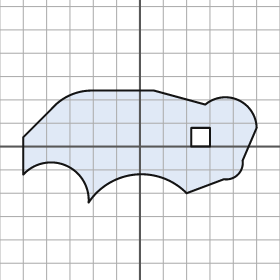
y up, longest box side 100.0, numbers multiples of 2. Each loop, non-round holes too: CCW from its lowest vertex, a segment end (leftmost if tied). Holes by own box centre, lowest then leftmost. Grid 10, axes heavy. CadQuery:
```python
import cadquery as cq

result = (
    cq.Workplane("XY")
    .moveTo(-22.0, -24.0)
    .threePointArc((-2.0, -12.0), (20.0, -20.0))
    .lineTo(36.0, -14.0)
    .threePointArc((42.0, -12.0), (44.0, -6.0))
    .lineTo(50.0, 8.0)
    .threePointArc((42.0, 20.0), (28.0, 18.0))
    .lineTo(6.0, 24.0)
    .lineTo(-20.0, 24.0)
    .threePointArc((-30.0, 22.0), (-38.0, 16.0))
    .lineTo(-50.0, 4.0)
    .lineTo(-50.0, -12.0)
    .threePointArc((-32.0, -8.0), (-22.0, -24.0))
    .close()
    .moveTo(22.0, 0.0)
    .lineTo(30.0, 0.0)
    .lineTo(30.0, 8.0)
    .lineTo(22.0, 8.0)
    .close()
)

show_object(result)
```